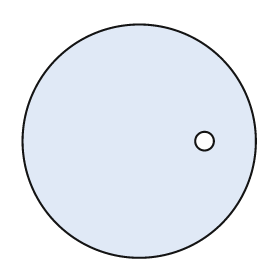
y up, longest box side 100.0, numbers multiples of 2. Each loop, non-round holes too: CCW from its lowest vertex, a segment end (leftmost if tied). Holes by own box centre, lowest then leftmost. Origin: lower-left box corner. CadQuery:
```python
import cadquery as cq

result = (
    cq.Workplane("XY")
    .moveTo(50.0, 50.0)
    .circle(50.0)
    .moveTo(78.0, 50.0)
    .circle(4.0)
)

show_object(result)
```